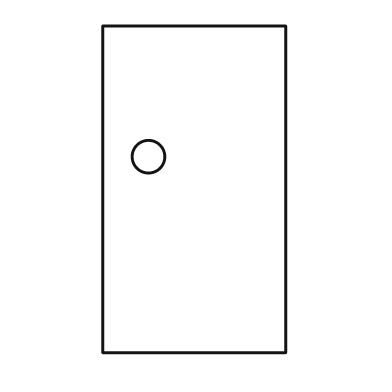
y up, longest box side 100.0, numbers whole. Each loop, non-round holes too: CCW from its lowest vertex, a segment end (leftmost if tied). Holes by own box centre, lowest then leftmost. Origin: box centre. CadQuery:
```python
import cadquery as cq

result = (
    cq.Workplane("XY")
    .moveTo(-28.0, -50.0)
    .lineTo(28.0, -50.0)
    .lineTo(28.0, 50.0)
    .lineTo(-28.0, 50.0)
    .close()
    .moveTo(-14.0, 10.0)
    .circle(5.0)
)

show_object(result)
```